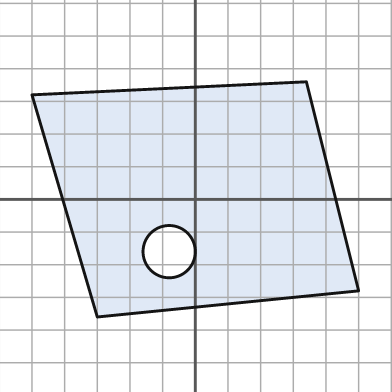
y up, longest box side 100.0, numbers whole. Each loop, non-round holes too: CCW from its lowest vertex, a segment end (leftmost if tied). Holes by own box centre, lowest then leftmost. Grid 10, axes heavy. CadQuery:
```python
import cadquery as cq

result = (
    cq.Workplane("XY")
    .moveTo(-30.0, -36.0)
    .lineTo(50.0, -28.0)
    .lineTo(34.0, 36.0)
    .lineTo(-50.0, 32.0)
    .close()
    .moveTo(-8.0, -16.0)
    .circle(8.0)
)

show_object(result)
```